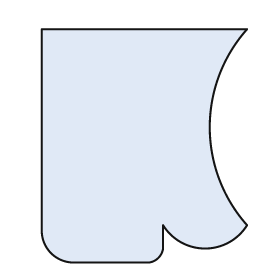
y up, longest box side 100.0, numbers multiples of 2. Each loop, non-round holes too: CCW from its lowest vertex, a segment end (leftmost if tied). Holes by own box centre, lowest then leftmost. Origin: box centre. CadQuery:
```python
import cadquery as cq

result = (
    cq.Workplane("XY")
    .moveTo(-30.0, -50.0)
    .lineTo(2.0, -50.0)
    .threePointArc((6.0, -48.0), (8.0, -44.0))
    .lineTo(8.0, -34.0)
    .threePointArc((26.0, -44.0), (44.0, -34.0))
    .threePointArc((28.0, 8.0), (44.0, 50.0))
    .lineTo(-44.0, 50.0)
    .lineTo(-44.0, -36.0)
    .threePointArc((-40.0, -46.0), (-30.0, -50.0))
    .close()
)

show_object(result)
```